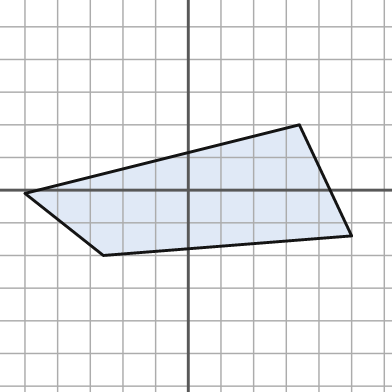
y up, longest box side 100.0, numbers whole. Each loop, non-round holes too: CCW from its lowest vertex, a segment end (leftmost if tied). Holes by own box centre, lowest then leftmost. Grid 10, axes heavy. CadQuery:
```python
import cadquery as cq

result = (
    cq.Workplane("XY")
    .moveTo(-26.0, -20.0)
    .lineTo(50.0, -14.0)
    .lineTo(34.0, 20.0)
    .lineTo(-50.0, -1.0)
    .close()
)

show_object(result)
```